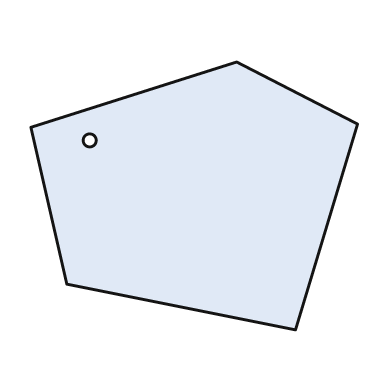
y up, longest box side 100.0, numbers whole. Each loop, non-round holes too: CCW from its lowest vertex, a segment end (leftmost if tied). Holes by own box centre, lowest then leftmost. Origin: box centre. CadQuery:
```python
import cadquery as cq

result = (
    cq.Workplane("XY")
    .moveTo(31.0, -41.0)
    .lineTo(50.0, 22.0)
    .lineTo(13.0, 41.0)
    .lineTo(-50.0, 21.0)
    .lineTo(-39.0, -27.0)
    .close()
    .moveTo(-32.0, 17.0)
    .circle(2.0)
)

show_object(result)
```